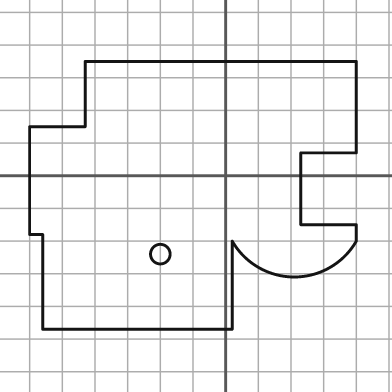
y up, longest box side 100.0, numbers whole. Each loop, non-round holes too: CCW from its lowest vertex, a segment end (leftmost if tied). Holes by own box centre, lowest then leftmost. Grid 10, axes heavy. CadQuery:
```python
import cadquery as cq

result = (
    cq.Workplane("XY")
    .moveTo(-56.0, -47.0)
    .lineTo(2.0, -47.0)
    .lineTo(2.0, -20.0)
    .threePointArc((21.0, -31.0), (40.0, -20.0))
    .lineTo(40.0, -15.0)
    .lineTo(23.0, -15.0)
    .lineTo(23.0, 7.0)
    .lineTo(40.0, 7.0)
    .lineTo(40.0, 35.0)
    .lineTo(-43.0, 35.0)
    .lineTo(-43.0, 15.0)
    .lineTo(-60.0, 15.0)
    .lineTo(-60.0, -18.0)
    .lineTo(-56.0, -18.0)
    .close()
    .moveTo(-20.0, -24.0)
    .circle(3.0)
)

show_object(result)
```